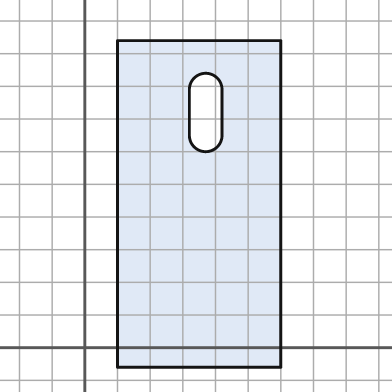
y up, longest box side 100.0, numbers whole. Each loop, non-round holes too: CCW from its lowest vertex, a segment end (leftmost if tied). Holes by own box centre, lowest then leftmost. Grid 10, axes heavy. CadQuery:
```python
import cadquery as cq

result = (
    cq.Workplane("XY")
    .moveTo(10.0, -6.0)
    .lineTo(60.0, -6.0)
    .lineTo(60.0, 94.0)
    .lineTo(10.0, 94.0)
    .close()
    .moveTo(32.0, 65.0)
    .threePointArc((37.0, 60.0), (42.0, 65.0))
    .lineTo(42.0, 79.0)
    .threePointArc((37.0, 84.0), (32.0, 79.0))
    .close()
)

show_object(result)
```